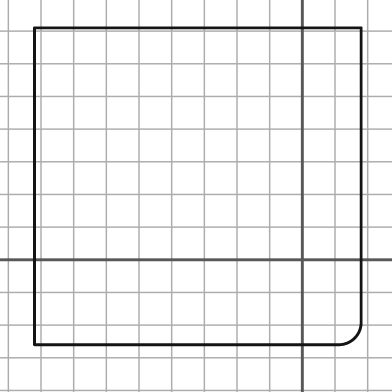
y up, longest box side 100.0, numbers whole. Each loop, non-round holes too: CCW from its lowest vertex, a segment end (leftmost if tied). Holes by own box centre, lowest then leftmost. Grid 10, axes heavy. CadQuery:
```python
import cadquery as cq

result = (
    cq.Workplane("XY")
    .moveTo(-82.0, -26.0)
    .lineTo(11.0, -26.0)
    .threePointArc((16.0, -24.0), (18.0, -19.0))
    .lineTo(18.0, 71.0)
    .lineTo(-82.0, 71.0)
    .close()
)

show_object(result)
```